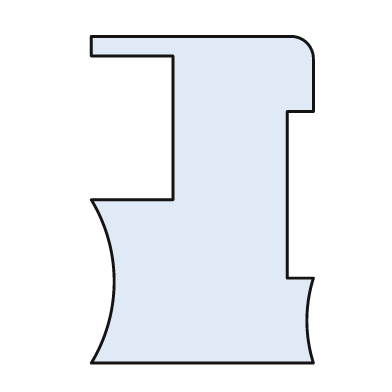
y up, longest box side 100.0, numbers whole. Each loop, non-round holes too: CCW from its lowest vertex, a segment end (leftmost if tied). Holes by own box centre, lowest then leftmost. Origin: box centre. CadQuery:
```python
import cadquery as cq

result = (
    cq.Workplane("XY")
    .moveTo(-34.0, -50.0)
    .lineTo(34.0, -50.0)
    .threePointArc((32.0, -37.0), (34.0, -24.0))
    .lineTo(26.0, -24.0)
    .lineTo(26.0, 27.0)
    .lineTo(34.0, 27.0)
    .lineTo(34.0, 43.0)
    .threePointArc((32.0, 48.0), (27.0, 50.0))
    .lineTo(-34.0, 50.0)
    .lineTo(-34.0, 44.0)
    .lineTo(-9.0, 44.0)
    .lineTo(-9.0, 0.0)
    .lineTo(-34.0, 0.0)
    .threePointArc((-27.0, -25.0), (-34.0, -50.0))
    .close()
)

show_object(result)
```